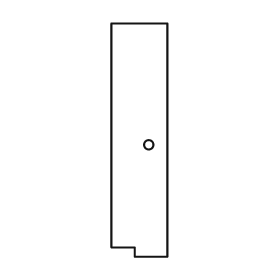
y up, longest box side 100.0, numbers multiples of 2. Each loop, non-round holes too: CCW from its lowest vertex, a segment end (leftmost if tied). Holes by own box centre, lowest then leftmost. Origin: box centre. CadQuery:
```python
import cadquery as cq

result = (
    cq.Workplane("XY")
    .moveTo(-2.0, -50.0)
    .lineTo(12.0, -50.0)
    .lineTo(12.0, 50.0)
    .lineTo(-12.0, 50.0)
    .lineTo(-12.0, -46.0)
    .lineTo(-2.0, -46.0)
    .close()
    .moveTo(4.0, -2.0)
    .circle(2.0)
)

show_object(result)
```